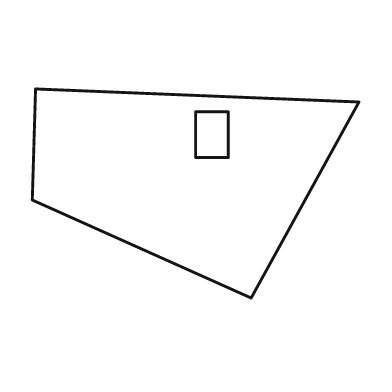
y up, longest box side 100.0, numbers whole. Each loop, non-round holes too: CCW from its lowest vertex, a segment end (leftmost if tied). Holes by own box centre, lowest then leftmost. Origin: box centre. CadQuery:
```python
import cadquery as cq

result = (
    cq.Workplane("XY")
    .moveTo(17.0, -32.0)
    .lineTo(50.0, 28.0)
    .lineTo(-49.0, 32.0)
    .lineTo(-50.0, -2.0)
    .close()
    .moveTo(0.0, 11.0)
    .lineTo(10.0, 11.0)
    .lineTo(10.0, 25.0)
    .lineTo(0.0, 25.0)
    .close()
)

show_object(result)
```